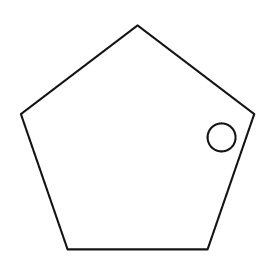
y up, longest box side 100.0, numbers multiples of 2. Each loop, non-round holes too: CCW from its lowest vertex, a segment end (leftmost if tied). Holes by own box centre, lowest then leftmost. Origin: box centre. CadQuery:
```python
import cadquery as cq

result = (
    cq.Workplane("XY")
    .moveTo(-30.0, -48.0)
    .lineTo(30.0, -48.0)
    .lineTo(50.0, 10.0)
    .lineTo(0.0, 48.0)
    .lineTo(-50.0, 10.0)
    .close()
    .moveTo(36.0, 0.0)
    .circle(6.0)
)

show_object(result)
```